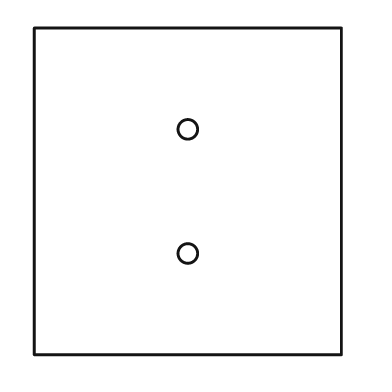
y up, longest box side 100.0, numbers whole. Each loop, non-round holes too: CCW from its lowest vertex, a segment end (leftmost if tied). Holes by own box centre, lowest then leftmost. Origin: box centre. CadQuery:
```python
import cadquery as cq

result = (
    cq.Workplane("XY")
    .moveTo(-47.0, -50.0)
    .lineTo(47.0, -50.0)
    .lineTo(47.0, 50.0)
    .lineTo(-47.0, 50.0)
    .close()
    .moveTo(0.0, -19.0)
    .circle(3.0)
    .moveTo(0.0, 19.0)
    .circle(3.0)
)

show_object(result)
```